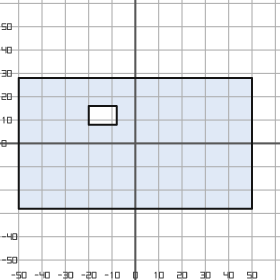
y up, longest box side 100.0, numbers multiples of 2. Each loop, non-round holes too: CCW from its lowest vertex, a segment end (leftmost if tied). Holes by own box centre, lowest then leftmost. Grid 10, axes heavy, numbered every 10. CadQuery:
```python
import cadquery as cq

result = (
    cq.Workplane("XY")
    .moveTo(-50.0, -28.0)
    .lineTo(50.0, -28.0)
    .lineTo(50.0, 28.0)
    .lineTo(-50.0, 28.0)
    .close()
    .moveTo(-20.0, 8.0)
    .lineTo(-8.0, 8.0)
    .lineTo(-8.0, 16.0)
    .lineTo(-20.0, 16.0)
    .close()
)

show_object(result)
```